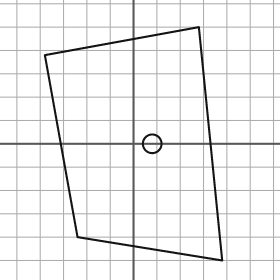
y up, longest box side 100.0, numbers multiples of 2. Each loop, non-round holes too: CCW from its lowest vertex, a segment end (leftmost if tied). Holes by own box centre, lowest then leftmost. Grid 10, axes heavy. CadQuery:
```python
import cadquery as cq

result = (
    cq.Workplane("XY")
    .moveTo(38.0, -50.0)
    .lineTo(28.0, 50.0)
    .lineTo(-38.0, 38.0)
    .lineTo(-24.0, -40.0)
    .close()
    .moveTo(8.0, 0.0)
    .circle(4.0)
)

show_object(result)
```